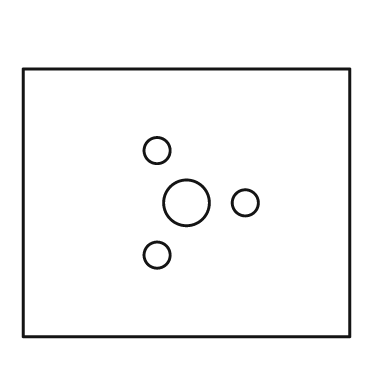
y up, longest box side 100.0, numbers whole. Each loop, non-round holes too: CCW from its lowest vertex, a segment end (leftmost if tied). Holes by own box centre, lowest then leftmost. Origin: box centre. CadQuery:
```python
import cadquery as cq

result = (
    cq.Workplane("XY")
    .moveTo(-50.0, -41.0)
    .lineTo(50.0, -41.0)
    .lineTo(50.0, 41.0)
    .lineTo(-50.0, 41.0)
    .close()
    .moveTo(-9.0, -16.0)
    .circle(4.0)
    .moveTo(0.0, 0.0)
    .circle(7.0)
    .moveTo(18.0, 0.0)
    .circle(4.0)
    .moveTo(-9.0, 16.0)
    .circle(4.0)
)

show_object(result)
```